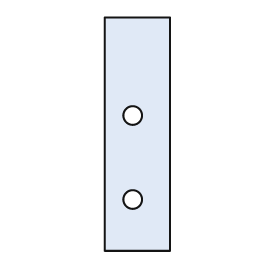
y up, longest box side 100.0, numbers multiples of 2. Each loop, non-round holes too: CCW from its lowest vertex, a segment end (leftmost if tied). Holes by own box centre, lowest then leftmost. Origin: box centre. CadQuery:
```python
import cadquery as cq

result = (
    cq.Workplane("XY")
    .moveTo(-14.0, -50.0)
    .lineTo(14.0, -50.0)
    .lineTo(14.0, 50.0)
    .lineTo(-14.0, 50.0)
    .close()
    .moveTo(-2.0, -28.0)
    .circle(4.0)
    .moveTo(-2.0, 8.0)
    .circle(4.0)
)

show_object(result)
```